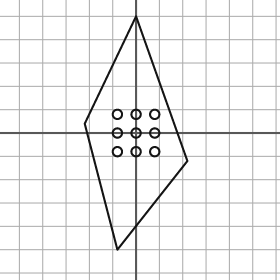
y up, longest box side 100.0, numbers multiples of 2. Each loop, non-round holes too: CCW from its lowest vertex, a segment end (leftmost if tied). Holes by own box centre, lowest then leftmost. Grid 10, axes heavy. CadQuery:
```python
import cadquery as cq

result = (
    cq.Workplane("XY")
    .moveTo(-8.0, -50.0)
    .lineTo(22.0, -12.0)
    .lineTo(0.0, 50.0)
    .lineTo(-22.0, 4.0)
    .close()
    .moveTo(-8.0, -8.0)
    .circle(2.0)
    .moveTo(0.0, -8.0)
    .circle(2.0)
    .moveTo(8.0, -8.0)
    .circle(2.0)
    .moveTo(-8.0, 0.0)
    .circle(2.0)
    .moveTo(0.0, 0.0)
    .circle(2.0)
    .moveTo(8.0, 0.0)
    .circle(2.0)
    .moveTo(-8.0, 8.0)
    .circle(2.0)
    .moveTo(0.0, 8.0)
    .circle(2.0)
    .moveTo(8.0, 8.0)
    .circle(2.0)
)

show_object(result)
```